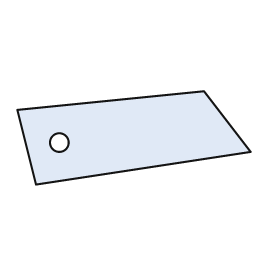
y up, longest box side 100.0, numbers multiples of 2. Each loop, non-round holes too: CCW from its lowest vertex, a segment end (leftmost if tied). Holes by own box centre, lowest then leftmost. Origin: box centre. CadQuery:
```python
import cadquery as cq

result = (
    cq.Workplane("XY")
    .moveTo(-42.0, -20.0)
    .lineTo(50.0, -6.0)
    .lineTo(30.0, 20.0)
    .lineTo(-50.0, 12.0)
    .close()
    .moveTo(-32.0, -2.0)
    .circle(4.0)
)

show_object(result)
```